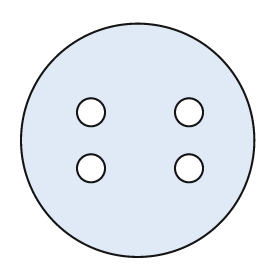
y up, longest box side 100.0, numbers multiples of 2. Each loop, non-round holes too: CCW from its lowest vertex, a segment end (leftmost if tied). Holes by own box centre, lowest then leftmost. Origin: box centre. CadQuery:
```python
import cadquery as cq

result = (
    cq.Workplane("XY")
    .moveTo(0.0, 0.0)
    .circle(50.0)
    .moveTo(-20.0, -12.0)
    .circle(6.0)
    .moveTo(22.0, -12.0)
    .circle(6.0)
    .moveTo(-20.0, 12.0)
    .circle(6.0)
    .moveTo(22.0, 12.0)
    .circle(6.0)
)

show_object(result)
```